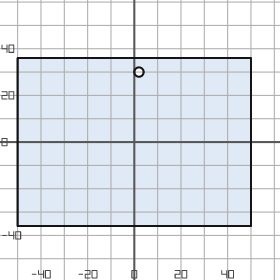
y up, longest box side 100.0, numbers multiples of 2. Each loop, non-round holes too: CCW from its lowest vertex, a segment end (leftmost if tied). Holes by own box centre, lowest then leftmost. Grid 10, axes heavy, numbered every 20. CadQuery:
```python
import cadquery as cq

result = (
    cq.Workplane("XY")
    .moveTo(-50.0, -36.0)
    .lineTo(50.0, -36.0)
    .lineTo(50.0, 36.0)
    .lineTo(-50.0, 36.0)
    .close()
    .moveTo(2.0, 30.0)
    .circle(2.0)
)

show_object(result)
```